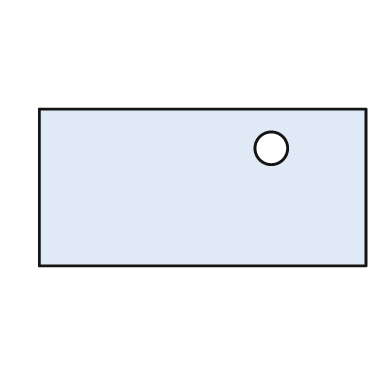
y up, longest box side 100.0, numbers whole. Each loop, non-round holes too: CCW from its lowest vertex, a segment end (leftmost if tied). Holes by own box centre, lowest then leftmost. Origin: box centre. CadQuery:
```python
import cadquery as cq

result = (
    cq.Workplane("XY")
    .moveTo(-50.0, -24.0)
    .lineTo(50.0, -24.0)
    .lineTo(50.0, 24.0)
    .lineTo(-50.0, 24.0)
    .close()
    .moveTo(21.0, 12.0)
    .circle(5.0)
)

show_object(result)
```